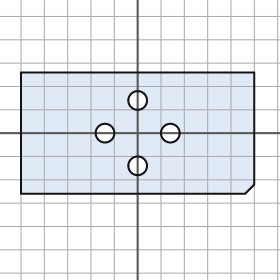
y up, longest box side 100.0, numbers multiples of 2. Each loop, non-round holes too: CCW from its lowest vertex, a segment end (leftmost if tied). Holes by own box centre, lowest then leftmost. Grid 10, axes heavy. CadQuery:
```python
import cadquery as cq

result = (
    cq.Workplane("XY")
    .moveTo(-50.0, -26.0)
    .lineTo(46.0, -26.0)
    .lineTo(50.0, -22.0)
    .lineTo(50.0, 26.0)
    .lineTo(-50.0, 26.0)
    .close()
    .moveTo(0.0, -14.0)
    .circle(4.0)
    .moveTo(-14.0, 0.0)
    .circle(4.0)
    .moveTo(14.0, 0.0)
    .circle(4.0)
    .moveTo(0.0, 14.0)
    .circle(4.0)
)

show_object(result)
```